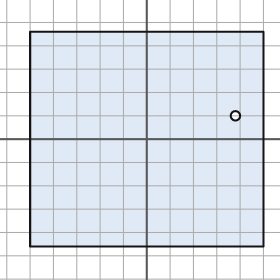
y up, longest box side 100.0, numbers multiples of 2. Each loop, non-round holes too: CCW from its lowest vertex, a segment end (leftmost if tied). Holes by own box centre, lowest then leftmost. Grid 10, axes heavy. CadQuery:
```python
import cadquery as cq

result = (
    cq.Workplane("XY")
    .moveTo(-50.0, -46.0)
    .lineTo(50.0, -46.0)
    .lineTo(50.0, 46.0)
    .lineTo(-50.0, 46.0)
    .close()
    .moveTo(38.0, 10.0)
    .circle(2.0)
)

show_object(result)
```